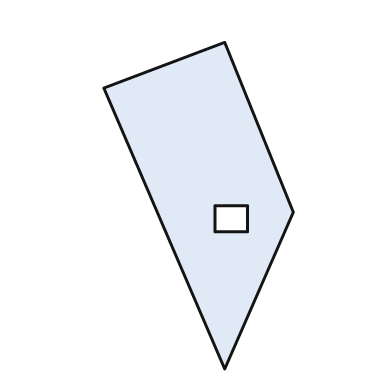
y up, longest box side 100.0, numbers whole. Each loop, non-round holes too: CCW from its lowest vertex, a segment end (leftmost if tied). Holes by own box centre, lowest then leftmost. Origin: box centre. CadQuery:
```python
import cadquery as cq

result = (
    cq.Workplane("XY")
    .moveTo(8.0, -50.0)
    .lineTo(29.0, -2.0)
    .lineTo(8.0, 50.0)
    .lineTo(-29.0, 36.0)
    .close()
    .moveTo(5.0, -8.0)
    .lineTo(15.0, -8.0)
    .lineTo(15.0, 0.0)
    .lineTo(5.0, 0.0)
    .close()
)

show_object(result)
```